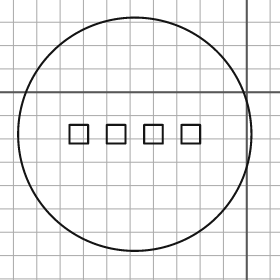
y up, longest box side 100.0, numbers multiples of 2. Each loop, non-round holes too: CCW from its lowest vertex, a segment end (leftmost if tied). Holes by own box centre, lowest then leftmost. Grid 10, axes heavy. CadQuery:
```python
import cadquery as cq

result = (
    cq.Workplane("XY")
    .moveTo(-48.0, -18.0)
    .circle(50.0)
    .moveTo(-76.0, -22.0)
    .lineTo(-68.0, -22.0)
    .lineTo(-68.0, -14.0)
    .lineTo(-76.0, -14.0)
    .close()
    .moveTo(-60.0, -22.0)
    .lineTo(-52.0, -22.0)
    .lineTo(-52.0, -14.0)
    .lineTo(-60.0, -14.0)
    .close()
    .moveTo(-44.0, -22.0)
    .lineTo(-36.0, -22.0)
    .lineTo(-36.0, -14.0)
    .lineTo(-44.0, -14.0)
    .close()
    .moveTo(-28.0, -22.0)
    .lineTo(-20.0, -22.0)
    .lineTo(-20.0, -14.0)
    .lineTo(-28.0, -14.0)
    .close()
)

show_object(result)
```